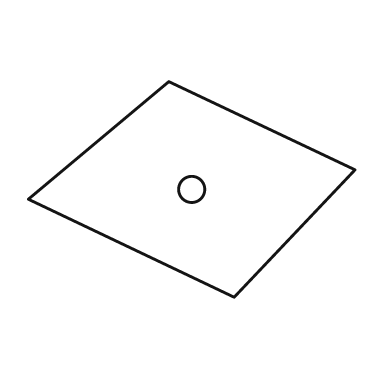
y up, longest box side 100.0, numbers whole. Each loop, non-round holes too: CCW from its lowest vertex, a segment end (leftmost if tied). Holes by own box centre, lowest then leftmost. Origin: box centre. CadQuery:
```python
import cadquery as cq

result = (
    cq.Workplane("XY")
    .moveTo(13.0, -33.0)
    .lineTo(50.0, 6.0)
    .lineTo(-7.0, 33.0)
    .lineTo(-50.0, -3.0)
    .close()
    .moveTo(0.0, 0.0)
    .circle(4.0)
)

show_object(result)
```